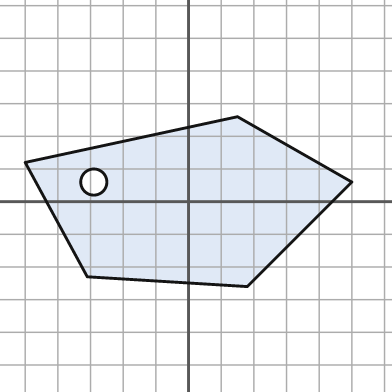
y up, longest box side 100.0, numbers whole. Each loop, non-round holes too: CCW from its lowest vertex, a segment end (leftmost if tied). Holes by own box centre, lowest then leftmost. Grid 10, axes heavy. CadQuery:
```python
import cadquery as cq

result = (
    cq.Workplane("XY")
    .moveTo(18.0, -26.0)
    .lineTo(50.0, 6.0)
    .lineTo(15.0, 26.0)
    .lineTo(-50.0, 12.0)
    .lineTo(-31.0, -23.0)
    .close()
    .moveTo(-29.0, 6.0)
    .circle(4.0)
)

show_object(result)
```